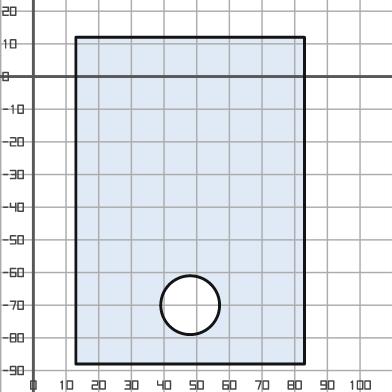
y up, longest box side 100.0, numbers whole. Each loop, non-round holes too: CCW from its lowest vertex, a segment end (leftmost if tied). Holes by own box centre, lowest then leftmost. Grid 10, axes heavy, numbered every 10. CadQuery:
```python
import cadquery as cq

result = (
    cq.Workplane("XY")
    .moveTo(13.0, -88.0)
    .lineTo(83.0, -88.0)
    .lineTo(83.0, 12.0)
    .lineTo(13.0, 12.0)
    .close()
    .moveTo(48.0, -70.0)
    .circle(9.0)
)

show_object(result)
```